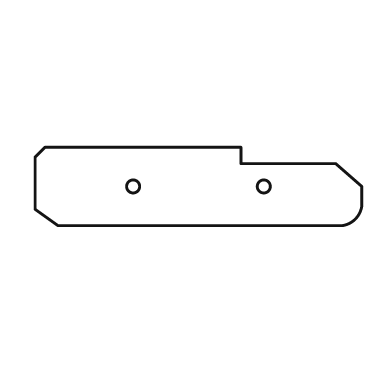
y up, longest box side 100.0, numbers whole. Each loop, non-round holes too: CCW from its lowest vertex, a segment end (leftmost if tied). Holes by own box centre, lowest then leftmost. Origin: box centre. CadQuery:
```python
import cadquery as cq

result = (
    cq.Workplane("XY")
    .moveTo(-43.0, -12.0)
    .lineTo(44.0, -12.0)
    .threePointArc((48.0, -10.0), (50.0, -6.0))
    .lineTo(50.0, 0.0)
    .lineTo(42.0, 7.0)
    .lineTo(13.0, 7.0)
    .lineTo(13.0, 12.0)
    .lineTo(-47.0, 12.0)
    .lineTo(-50.0, 9.0)
    .lineTo(-50.0, -7.0)
    .close()
    .moveTo(-20.0, 0.0)
    .circle(2.0)
    .moveTo(20.0, 0.0)
    .circle(2.0)
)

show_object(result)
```